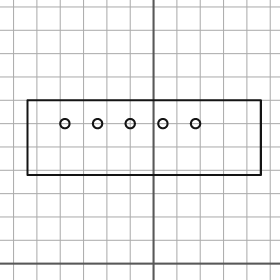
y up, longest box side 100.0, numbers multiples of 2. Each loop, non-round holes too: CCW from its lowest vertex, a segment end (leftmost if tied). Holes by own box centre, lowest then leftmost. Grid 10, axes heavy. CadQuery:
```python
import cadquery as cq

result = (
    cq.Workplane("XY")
    .moveTo(-54.0, 38.0)
    .lineTo(46.0, 38.0)
    .lineTo(46.0, 70.0)
    .lineTo(-54.0, 70.0)
    .close()
    .moveTo(-38.0, 60.0)
    .circle(2.0)
    .moveTo(-24.0, 60.0)
    .circle(2.0)
    .moveTo(-10.0, 60.0)
    .circle(2.0)
    .moveTo(4.0, 60.0)
    .circle(2.0)
    .moveTo(18.0, 60.0)
    .circle(2.0)
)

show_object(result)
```